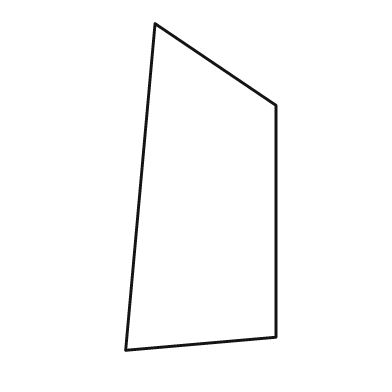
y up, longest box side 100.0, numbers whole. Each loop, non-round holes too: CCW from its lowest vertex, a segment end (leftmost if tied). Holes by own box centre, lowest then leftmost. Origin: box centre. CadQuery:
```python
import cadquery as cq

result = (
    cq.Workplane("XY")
    .moveTo(-23.0, -50.0)
    .lineTo(23.0, -46.0)
    .lineTo(23.0, 25.0)
    .lineTo(-14.0, 50.0)
    .close()
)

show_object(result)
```